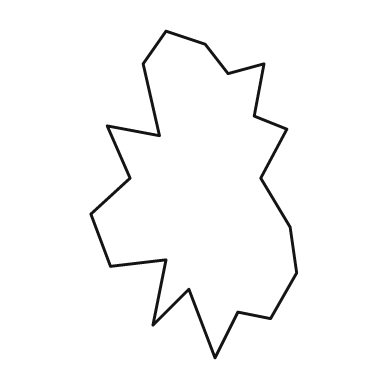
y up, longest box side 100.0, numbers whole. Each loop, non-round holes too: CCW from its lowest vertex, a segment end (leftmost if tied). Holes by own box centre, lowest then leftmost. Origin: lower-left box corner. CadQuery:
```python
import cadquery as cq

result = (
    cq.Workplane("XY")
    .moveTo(38.0, 0.0)
    .lineTo(45.0, 14.0)
    .lineTo(55.0, 12.0)
    .lineTo(63.0, 26.0)
    .lineTo(61.0, 40.0)
    .lineTo(52.0, 55.0)
    .lineTo(60.0, 70.0)
    .lineTo(50.0, 74.0)
    .lineTo(53.0, 90.0)
    .lineTo(42.0, 87.0)
    .lineTo(35.0, 96.0)
    .lineTo(23.0, 100.0)
    .lineTo(16.0, 90.0)
    .lineTo(21.0, 68.0)
    .lineTo(5.0, 71.0)
    .lineTo(12.0, 55.0)
    .lineTo(0.0, 44.0)
    .lineTo(6.0, 28.0)
    .lineTo(23.0, 30.0)
    .lineTo(19.0, 10.0)
    .lineTo(30.0, 21.0)
    .close()
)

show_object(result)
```